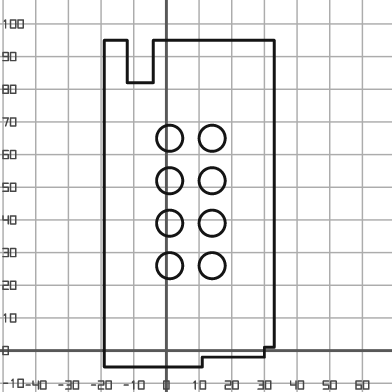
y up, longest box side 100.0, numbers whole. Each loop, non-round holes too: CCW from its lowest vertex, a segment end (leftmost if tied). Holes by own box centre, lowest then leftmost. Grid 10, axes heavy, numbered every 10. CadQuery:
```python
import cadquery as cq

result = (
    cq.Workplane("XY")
    .moveTo(-19.0, -5.0)
    .lineTo(11.0, -5.0)
    .lineTo(11.0, -2.0)
    .lineTo(30.0, -2.0)
    .lineTo(30.0, 1.0)
    .lineTo(33.0, 1.0)
    .lineTo(33.0, 95.0)
    .lineTo(-4.0, 95.0)
    .lineTo(-4.0, 82.0)
    .lineTo(-12.0, 82.0)
    .lineTo(-12.0, 95.0)
    .lineTo(-19.0, 95.0)
    .close()
    .moveTo(1.0, 26.0)
    .circle(4.0)
    .moveTo(14.0, 26.0)
    .circle(4.0)
    .moveTo(1.0, 39.0)
    .circle(4.0)
    .moveTo(14.0, 39.0)
    .circle(4.0)
    .moveTo(1.0, 52.0)
    .circle(4.0)
    .moveTo(14.0, 52.0)
    .circle(4.0)
    .moveTo(1.0, 65.0)
    .circle(4.0)
    .moveTo(14.0, 65.0)
    .circle(4.0)
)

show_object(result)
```